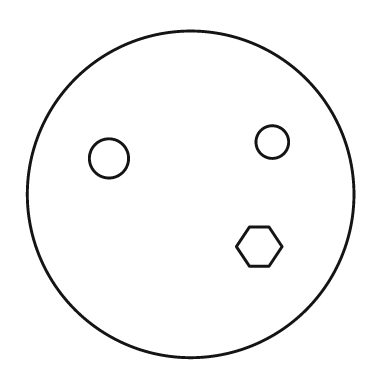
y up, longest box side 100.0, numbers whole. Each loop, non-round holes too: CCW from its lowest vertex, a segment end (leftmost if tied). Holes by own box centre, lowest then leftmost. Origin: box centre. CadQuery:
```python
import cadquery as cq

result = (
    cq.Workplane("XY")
    .moveTo(0.0, 0.0)
    .circle(50.0)
    .moveTo(18.0, -22.0)
    .lineTo(24.0, -22.0)
    .lineTo(28.0, -16.0)
    .lineTo(24.0, -10.0)
    .lineTo(18.0, -10.0)
    .lineTo(14.0, -16.0)
    .close()
    .moveTo(-25.0, 11.0)
    .circle(6.0)
    .moveTo(25.0, 16.0)
    .circle(5.0)
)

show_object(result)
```